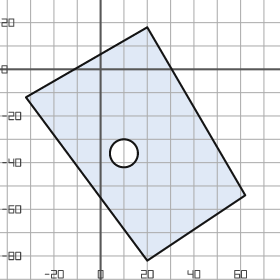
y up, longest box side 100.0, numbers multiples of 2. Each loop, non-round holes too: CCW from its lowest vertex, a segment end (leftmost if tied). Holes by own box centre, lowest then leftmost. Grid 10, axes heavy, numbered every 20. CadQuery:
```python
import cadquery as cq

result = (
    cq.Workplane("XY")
    .moveTo(20.0, -82.0)
    .lineTo(62.0, -54.0)
    .lineTo(20.0, 18.0)
    .lineTo(-32.0, -12.0)
    .close()
    .moveTo(10.0, -36.0)
    .circle(6.0)
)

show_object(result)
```